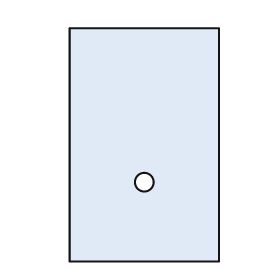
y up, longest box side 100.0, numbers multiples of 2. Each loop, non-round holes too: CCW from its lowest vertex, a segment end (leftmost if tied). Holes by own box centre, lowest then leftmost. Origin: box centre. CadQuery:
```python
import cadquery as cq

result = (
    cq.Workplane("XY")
    .moveTo(-32.0, -50.0)
    .lineTo(32.0, -50.0)
    .lineTo(32.0, 50.0)
    .lineTo(-32.0, 50.0)
    .close()
    .moveTo(0.0, -16.0)
    .circle(4.0)
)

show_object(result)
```